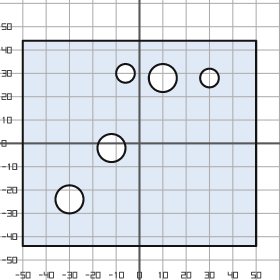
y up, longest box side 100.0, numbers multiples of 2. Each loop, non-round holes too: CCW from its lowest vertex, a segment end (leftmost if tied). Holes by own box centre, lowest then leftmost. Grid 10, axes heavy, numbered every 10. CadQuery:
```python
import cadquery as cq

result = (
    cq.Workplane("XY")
    .moveTo(-50.0, -44.0)
    .lineTo(50.0, -44.0)
    .lineTo(50.0, 44.0)
    .lineTo(-50.0, 44.0)
    .close()
    .moveTo(-30.0, -24.0)
    .circle(6.0)
    .moveTo(-12.0, -2.0)
    .circle(6.0)
    .moveTo(10.0, 28.0)
    .circle(6.0)
    .moveTo(30.0, 28.0)
    .circle(4.0)
    .moveTo(-6.0, 30.0)
    .circle(4.0)
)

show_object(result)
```